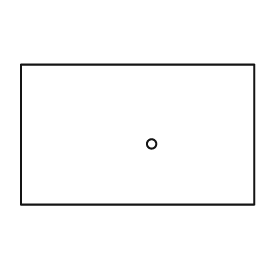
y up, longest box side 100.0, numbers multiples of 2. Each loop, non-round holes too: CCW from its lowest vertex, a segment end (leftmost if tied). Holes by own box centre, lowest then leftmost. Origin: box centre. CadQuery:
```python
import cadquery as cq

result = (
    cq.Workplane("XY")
    .moveTo(-50.0, -30.0)
    .lineTo(50.0, -30.0)
    .lineTo(50.0, 30.0)
    .lineTo(-50.0, 30.0)
    .close()
    .moveTo(6.0, -4.0)
    .circle(2.0)
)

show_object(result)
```